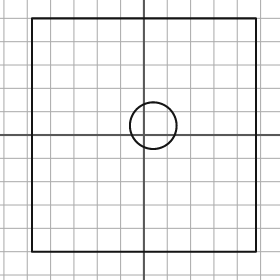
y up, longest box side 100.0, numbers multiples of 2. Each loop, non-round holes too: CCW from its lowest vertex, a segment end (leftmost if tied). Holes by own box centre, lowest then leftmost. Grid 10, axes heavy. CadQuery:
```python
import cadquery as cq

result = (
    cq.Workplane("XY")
    .moveTo(-48.0, -50.0)
    .lineTo(48.0, -50.0)
    .lineTo(48.0, 50.0)
    .lineTo(-48.0, 50.0)
    .close()
    .moveTo(4.0, 4.0)
    .circle(10.0)
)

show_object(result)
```